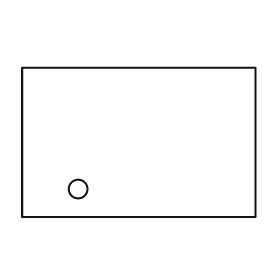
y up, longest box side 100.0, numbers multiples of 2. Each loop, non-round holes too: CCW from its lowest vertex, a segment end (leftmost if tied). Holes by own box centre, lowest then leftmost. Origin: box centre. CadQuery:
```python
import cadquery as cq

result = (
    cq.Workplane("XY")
    .moveTo(-50.0, -32.0)
    .lineTo(50.0, -32.0)
    .lineTo(50.0, 32.0)
    .lineTo(-50.0, 32.0)
    .close()
    .moveTo(-26.0, -20.0)
    .circle(4.0)
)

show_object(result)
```